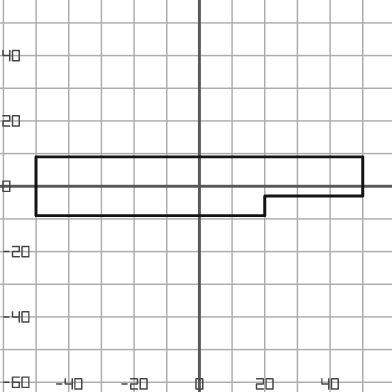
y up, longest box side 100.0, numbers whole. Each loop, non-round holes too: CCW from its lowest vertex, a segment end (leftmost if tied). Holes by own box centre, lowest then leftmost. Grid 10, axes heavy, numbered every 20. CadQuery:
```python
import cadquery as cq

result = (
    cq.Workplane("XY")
    .moveTo(-50.0, -9.0)
    .lineTo(20.0, -9.0)
    .lineTo(20.0, -3.0)
    .lineTo(50.0, -3.0)
    .lineTo(50.0, 9.0)
    .lineTo(-50.0, 9.0)
    .close()
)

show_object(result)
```